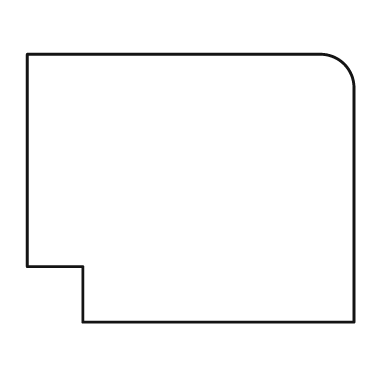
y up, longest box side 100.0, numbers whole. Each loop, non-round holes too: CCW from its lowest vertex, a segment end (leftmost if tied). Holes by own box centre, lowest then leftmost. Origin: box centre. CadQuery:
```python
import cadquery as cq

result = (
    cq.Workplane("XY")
    .moveTo(-33.0, -41.0)
    .lineTo(50.0, -41.0)
    .lineTo(50.0, 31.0)
    .threePointArc((47.0, 38.0), (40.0, 41.0))
    .lineTo(-50.0, 41.0)
    .lineTo(-50.0, -24.0)
    .lineTo(-33.0, -24.0)
    .close()
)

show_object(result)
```